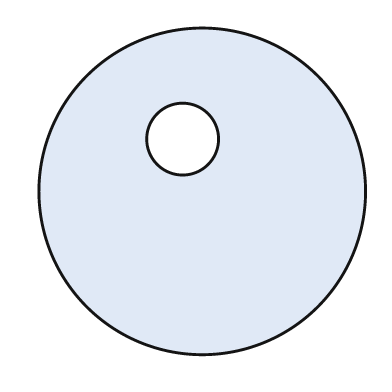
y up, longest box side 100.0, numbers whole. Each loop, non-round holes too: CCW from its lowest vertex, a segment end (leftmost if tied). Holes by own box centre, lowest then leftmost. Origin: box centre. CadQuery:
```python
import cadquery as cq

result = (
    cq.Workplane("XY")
    .moveTo(0.0, 0.0)
    .circle(50.0)
    .moveTo(-6.0, 16.0)
    .circle(11.0)
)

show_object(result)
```